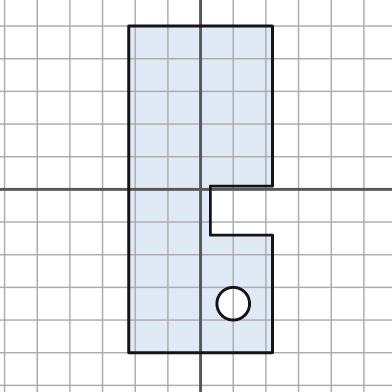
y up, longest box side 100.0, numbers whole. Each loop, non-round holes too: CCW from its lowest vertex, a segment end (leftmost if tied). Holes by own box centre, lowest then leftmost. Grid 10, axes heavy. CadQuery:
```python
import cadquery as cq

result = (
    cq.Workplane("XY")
    .moveTo(-22.0, -50.0)
    .lineTo(22.0, -50.0)
    .lineTo(22.0, -14.0)
    .lineTo(3.0, -14.0)
    .lineTo(3.0, 1.0)
    .lineTo(22.0, 1.0)
    .lineTo(22.0, 50.0)
    .lineTo(-22.0, 50.0)
    .close()
    .moveTo(10.0, -35.0)
    .circle(5.0)
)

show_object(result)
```